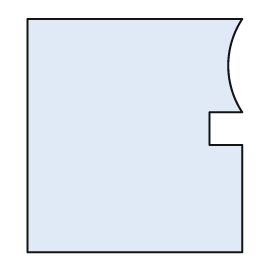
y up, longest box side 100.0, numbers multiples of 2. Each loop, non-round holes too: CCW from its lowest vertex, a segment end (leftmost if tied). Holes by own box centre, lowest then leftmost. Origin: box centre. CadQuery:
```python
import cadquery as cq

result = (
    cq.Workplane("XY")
    .moveTo(-46.0, -50.0)
    .lineTo(46.0, -50.0)
    .lineTo(46.0, -4.0)
    .lineTo(32.0, -4.0)
    .lineTo(32.0, 10.0)
    .lineTo(46.0, 10.0)
    .threePointArc((40.0, 30.0), (46.0, 50.0))
    .lineTo(-46.0, 50.0)
    .close()
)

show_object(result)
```